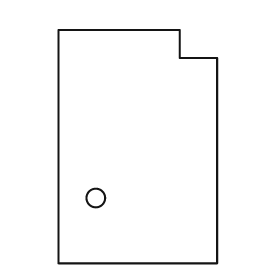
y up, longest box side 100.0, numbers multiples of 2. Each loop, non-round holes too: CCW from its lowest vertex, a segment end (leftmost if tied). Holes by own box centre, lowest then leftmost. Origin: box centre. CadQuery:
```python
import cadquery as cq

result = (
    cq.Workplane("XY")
    .moveTo(-34.0, -50.0)
    .lineTo(34.0, -50.0)
    .lineTo(34.0, 38.0)
    .lineTo(18.0, 38.0)
    .lineTo(18.0, 50.0)
    .lineTo(-34.0, 50.0)
    .close()
    .moveTo(-18.0, -22.0)
    .circle(4.0)
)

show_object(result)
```